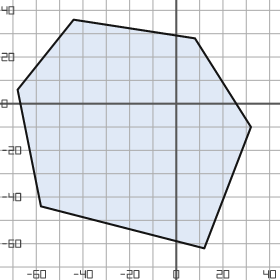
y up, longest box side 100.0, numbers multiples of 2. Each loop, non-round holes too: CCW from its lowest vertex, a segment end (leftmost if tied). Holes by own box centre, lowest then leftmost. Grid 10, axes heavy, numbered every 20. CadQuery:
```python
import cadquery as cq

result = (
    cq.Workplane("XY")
    .moveTo(12.0, -62.0)
    .lineTo(32.0, -10.0)
    .lineTo(8.0, 28.0)
    .lineTo(-44.0, 36.0)
    .lineTo(-68.0, 6.0)
    .lineTo(-58.0, -44.0)
    .close()
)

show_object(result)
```